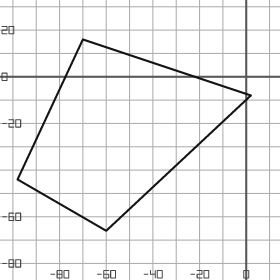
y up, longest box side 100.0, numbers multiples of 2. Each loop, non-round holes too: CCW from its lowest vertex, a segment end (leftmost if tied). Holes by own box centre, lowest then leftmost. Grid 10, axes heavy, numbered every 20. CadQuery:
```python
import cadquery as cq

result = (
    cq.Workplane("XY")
    .moveTo(-60.0, -66.0)
    .lineTo(2.0, -8.0)
    .lineTo(-70.0, 16.0)
    .lineTo(-98.0, -44.0)
    .close()
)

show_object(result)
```